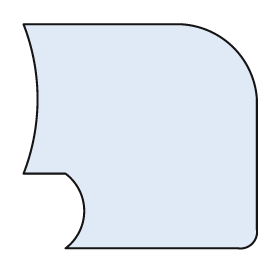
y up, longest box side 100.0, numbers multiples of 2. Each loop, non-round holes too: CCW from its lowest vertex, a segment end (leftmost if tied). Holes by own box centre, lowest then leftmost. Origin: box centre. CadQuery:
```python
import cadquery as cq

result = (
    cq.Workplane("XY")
    .moveTo(-32.0, -48.0)
    .lineTo(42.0, -48.0)
    .threePointArc((48.0, -46.0), (50.0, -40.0))
    .lineTo(50.0, 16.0)
    .threePointArc((40.0, 38.0), (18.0, 48.0))
    .lineTo(-50.0, 48.0)
    .threePointArc((-44.0, 16.0), (-50.0, -16.0))
    .lineTo(-32.0, -16.0)
    .threePointArc((-24.0, -32.0), (-32.0, -48.0))
    .close()
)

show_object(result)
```